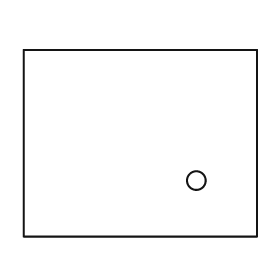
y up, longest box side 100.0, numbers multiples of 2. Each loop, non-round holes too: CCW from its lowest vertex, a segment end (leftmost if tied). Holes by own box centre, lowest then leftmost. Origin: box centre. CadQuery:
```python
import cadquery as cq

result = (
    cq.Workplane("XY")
    .moveTo(-50.0, -40.0)
    .lineTo(50.0, -40.0)
    .lineTo(50.0, 40.0)
    .lineTo(-50.0, 40.0)
    .close()
    .moveTo(24.0, -16.0)
    .circle(4.0)
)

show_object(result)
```